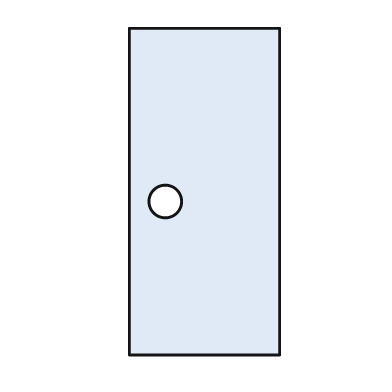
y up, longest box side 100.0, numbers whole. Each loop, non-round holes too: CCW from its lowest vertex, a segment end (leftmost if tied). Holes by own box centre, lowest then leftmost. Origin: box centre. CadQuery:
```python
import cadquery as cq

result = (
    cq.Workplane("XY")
    .moveTo(-23.0, -50.0)
    .lineTo(23.0, -50.0)
    .lineTo(23.0, 50.0)
    .lineTo(-23.0, 50.0)
    .close()
    .moveTo(-12.0, -3.0)
    .circle(5.0)
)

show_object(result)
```